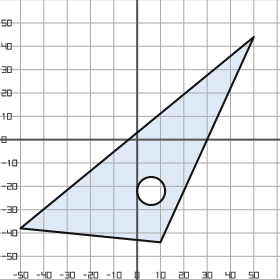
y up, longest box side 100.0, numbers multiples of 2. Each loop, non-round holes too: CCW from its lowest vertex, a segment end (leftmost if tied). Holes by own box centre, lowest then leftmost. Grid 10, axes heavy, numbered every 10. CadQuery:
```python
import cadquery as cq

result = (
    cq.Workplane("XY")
    .moveTo(10.0, -44.0)
    .lineTo(50.0, 44.0)
    .lineTo(-50.0, -38.0)
    .close()
    .moveTo(6.0, -22.0)
    .circle(6.0)
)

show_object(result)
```